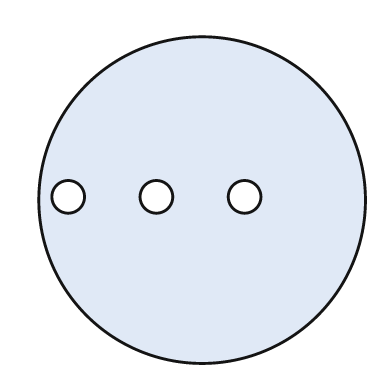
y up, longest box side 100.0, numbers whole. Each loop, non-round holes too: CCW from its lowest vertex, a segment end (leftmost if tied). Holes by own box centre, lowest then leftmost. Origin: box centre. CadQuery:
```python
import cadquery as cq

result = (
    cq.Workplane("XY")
    .moveTo(0.0, 0.0)
    .circle(50.0)
    .moveTo(-41.0, 1.0)
    .circle(5.0)
    .moveTo(-14.0, 1.0)
    .circle(5.0)
    .moveTo(13.0, 1.0)
    .circle(5.0)
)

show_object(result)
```